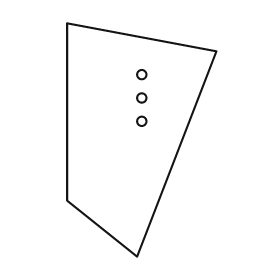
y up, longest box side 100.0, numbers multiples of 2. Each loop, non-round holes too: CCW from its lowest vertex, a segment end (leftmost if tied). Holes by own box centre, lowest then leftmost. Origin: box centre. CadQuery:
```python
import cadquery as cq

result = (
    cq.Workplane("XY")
    .moveTo(-2.0, -50.0)
    .lineTo(32.0, 38.0)
    .lineTo(-32.0, 50.0)
    .lineTo(-32.0, -26.0)
    .close()
    .moveTo(0.0, 8.0)
    .circle(2.0)
    .moveTo(0.0, 18.0)
    .circle(2.0)
    .moveTo(0.0, 28.0)
    .circle(2.0)
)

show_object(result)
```